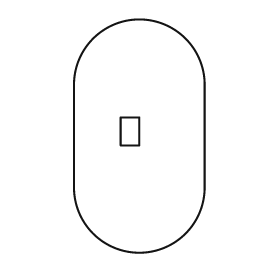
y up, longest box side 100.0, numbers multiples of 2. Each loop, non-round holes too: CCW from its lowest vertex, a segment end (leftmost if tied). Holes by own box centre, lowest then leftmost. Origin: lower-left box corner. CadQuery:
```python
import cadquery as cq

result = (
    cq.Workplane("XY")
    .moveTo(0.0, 28.0)
    .threePointArc((28.0, 0.0), (56.0, 28.0))
    .lineTo(56.0, 72.0)
    .threePointArc((28.0, 100.0), (0.0, 72.0))
    .close()
    .moveTo(20.0, 46.0)
    .lineTo(28.0, 46.0)
    .lineTo(28.0, 58.0)
    .lineTo(20.0, 58.0)
    .close()
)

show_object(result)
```